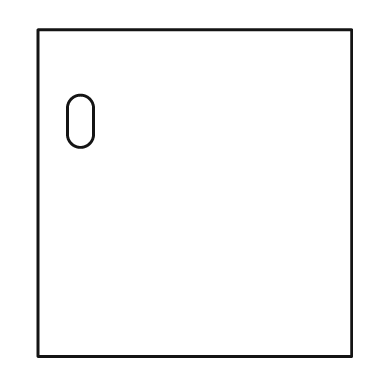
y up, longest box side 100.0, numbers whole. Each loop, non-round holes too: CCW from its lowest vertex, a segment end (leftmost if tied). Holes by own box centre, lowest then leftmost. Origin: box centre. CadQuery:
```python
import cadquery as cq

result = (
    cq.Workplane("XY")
    .moveTo(-48.0, -50.0)
    .lineTo(48.0, -50.0)
    .lineTo(48.0, 50.0)
    .lineTo(-48.0, 50.0)
    .close()
    .moveTo(-39.0, 18.0)
    .threePointArc((-35.0, 14.0), (-31.0, 18.0))
    .lineTo(-31.0, 26.0)
    .threePointArc((-35.0, 30.0), (-39.0, 26.0))
    .close()
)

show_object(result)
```